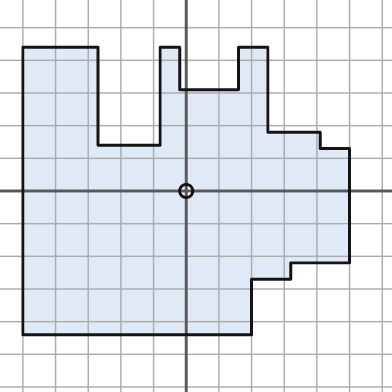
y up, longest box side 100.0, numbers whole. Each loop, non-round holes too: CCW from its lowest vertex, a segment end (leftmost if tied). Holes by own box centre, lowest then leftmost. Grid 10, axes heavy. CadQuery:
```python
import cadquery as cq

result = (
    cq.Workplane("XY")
    .moveTo(-50.0, -44.0)
    .lineTo(20.0, -44.0)
    .lineTo(20.0, -27.0)
    .lineTo(32.0, -27.0)
    .lineTo(32.0, -22.0)
    .lineTo(50.0, -22.0)
    .lineTo(50.0, 13.0)
    .lineTo(41.0, 13.0)
    .lineTo(41.0, 18.0)
    .lineTo(25.0, 18.0)
    .lineTo(25.0, 44.0)
    .lineTo(16.0, 44.0)
    .lineTo(16.0, 31.0)
    .lineTo(-2.0, 31.0)
    .lineTo(-2.0, 44.0)
    .lineTo(-8.0, 44.0)
    .lineTo(-8.0, 14.0)
    .lineTo(-27.0, 14.0)
    .lineTo(-27.0, 44.0)
    .lineTo(-50.0, 44.0)
    .close()
    .moveTo(0.0, 0.0)
    .circle(2.0)
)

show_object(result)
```